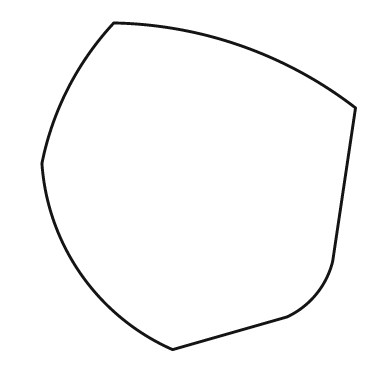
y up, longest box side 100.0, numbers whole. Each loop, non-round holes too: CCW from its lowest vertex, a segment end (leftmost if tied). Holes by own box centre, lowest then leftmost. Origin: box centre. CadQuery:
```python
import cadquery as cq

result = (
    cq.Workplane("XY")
    .moveTo(-8.0, -50.0)
    .lineTo(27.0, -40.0)
    .threePointArc((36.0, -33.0), (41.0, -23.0))
    .lineTo(48.0, 24.0)
    .threePointArc((13.0, 43.0), (-26.0, 50.0))
    .threePointArc((-40.0, 30.0), (-48.0, 7.0))
    .threePointArc((-36.0, -27.0), (-8.0, -50.0))
    .close()
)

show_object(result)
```